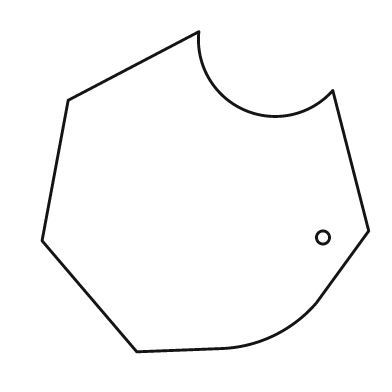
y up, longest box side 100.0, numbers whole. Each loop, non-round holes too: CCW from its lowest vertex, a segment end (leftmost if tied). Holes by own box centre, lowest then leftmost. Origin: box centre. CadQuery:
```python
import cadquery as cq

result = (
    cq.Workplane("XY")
    .moveTo(-21.0, -49.0)
    .lineTo(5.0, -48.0)
    .threePointArc((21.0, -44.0), (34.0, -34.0))
    .lineTo(50.0, -12.0)
    .lineTo(39.0, 31.0)
    .threePointArc((12.0, 25.0), (-2.0, 49.0))
    .lineTo(-42.0, 28.0)
    .lineTo(-50.0, -15.0)
    .close()
    .moveTo(36.0, -14.0)
    .circle(2.0)
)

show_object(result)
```